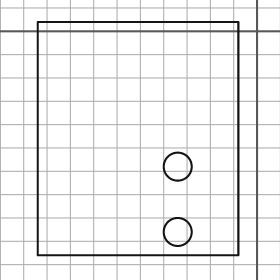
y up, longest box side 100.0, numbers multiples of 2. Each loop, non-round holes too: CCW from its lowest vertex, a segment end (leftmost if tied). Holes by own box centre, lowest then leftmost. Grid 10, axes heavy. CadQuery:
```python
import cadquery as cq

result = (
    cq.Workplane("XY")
    .moveTo(-94.0, -96.0)
    .lineTo(-8.0, -96.0)
    .lineTo(-8.0, 4.0)
    .lineTo(-94.0, 4.0)
    .close()
    .moveTo(-34.0, -86.0)
    .circle(6.0)
    .moveTo(-34.0, -58.0)
    .circle(6.0)
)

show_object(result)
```